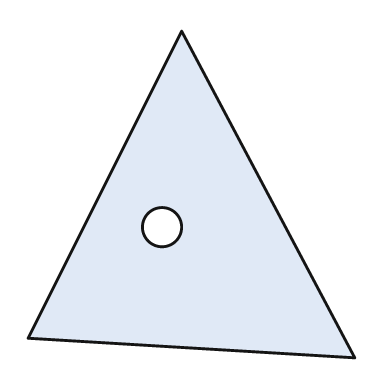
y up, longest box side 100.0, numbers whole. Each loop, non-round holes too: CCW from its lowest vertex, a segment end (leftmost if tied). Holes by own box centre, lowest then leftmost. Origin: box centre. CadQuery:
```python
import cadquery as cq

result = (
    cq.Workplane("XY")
    .moveTo(50.0, -50.0)
    .lineTo(-3.0, 50.0)
    .lineTo(-50.0, -44.0)
    .close()
    .moveTo(-9.0, -10.0)
    .circle(6.0)
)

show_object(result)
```